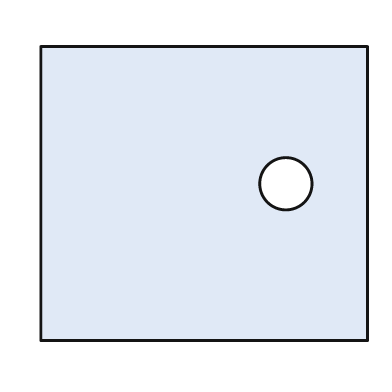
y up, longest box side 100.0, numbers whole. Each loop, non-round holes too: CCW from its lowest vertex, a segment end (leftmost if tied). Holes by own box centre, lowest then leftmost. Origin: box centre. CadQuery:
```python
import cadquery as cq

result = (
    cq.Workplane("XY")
    .moveTo(-50.0, -45.0)
    .lineTo(50.0, -45.0)
    .lineTo(50.0, 45.0)
    .lineTo(-50.0, 45.0)
    .close()
    .moveTo(25.0, 3.0)
    .circle(8.0)
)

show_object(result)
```